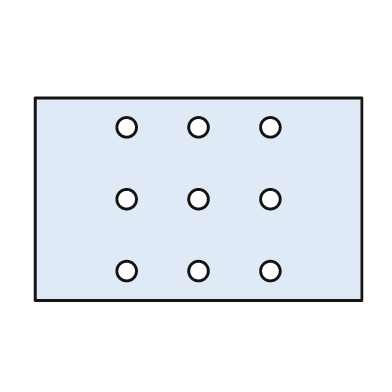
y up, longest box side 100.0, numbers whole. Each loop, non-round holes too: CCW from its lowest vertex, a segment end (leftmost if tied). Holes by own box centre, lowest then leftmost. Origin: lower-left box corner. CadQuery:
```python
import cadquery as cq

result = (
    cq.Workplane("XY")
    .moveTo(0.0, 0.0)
    .lineTo(100.0, 0.0)
    .lineTo(100.0, 62.0)
    .lineTo(0.0, 62.0)
    .close()
    .moveTo(28.0, 9.0)
    .circle(3.0)
    .moveTo(50.0, 9.0)
    .circle(3.0)
    .moveTo(72.0, 9.0)
    .circle(3.0)
    .moveTo(28.0, 31.0)
    .circle(3.0)
    .moveTo(50.0, 31.0)
    .circle(3.0)
    .moveTo(72.0, 31.0)
    .circle(3.0)
    .moveTo(28.0, 53.0)
    .circle(3.0)
    .moveTo(50.0, 53.0)
    .circle(3.0)
    .moveTo(72.0, 53.0)
    .circle(3.0)
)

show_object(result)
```